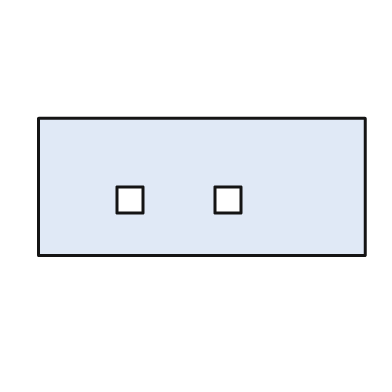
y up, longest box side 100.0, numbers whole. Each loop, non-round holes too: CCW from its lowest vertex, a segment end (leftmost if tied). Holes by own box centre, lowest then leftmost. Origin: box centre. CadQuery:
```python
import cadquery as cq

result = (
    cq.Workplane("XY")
    .moveTo(-50.0, -21.0)
    .lineTo(50.0, -21.0)
    .lineTo(50.0, 21.0)
    .lineTo(-50.0, 21.0)
    .close()
    .moveTo(-26.0, -8.0)
    .lineTo(-18.0, -8.0)
    .lineTo(-18.0, 0.0)
    .lineTo(-26.0, 0.0)
    .close()
    .moveTo(4.0, -8.0)
    .lineTo(12.0, -8.0)
    .lineTo(12.0, 0.0)
    .lineTo(4.0, 0.0)
    .close()
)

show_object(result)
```